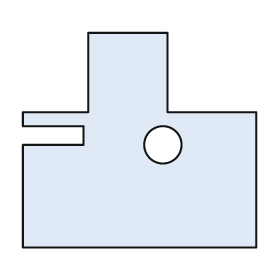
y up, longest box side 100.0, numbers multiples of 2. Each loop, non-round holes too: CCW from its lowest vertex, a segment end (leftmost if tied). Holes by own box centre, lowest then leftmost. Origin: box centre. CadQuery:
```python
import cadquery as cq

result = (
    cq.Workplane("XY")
    .moveTo(-50.0, -46.0)
    .lineTo(50.0, -46.0)
    .lineTo(50.0, 12.0)
    .lineTo(12.0, 12.0)
    .lineTo(12.0, 46.0)
    .lineTo(-22.0, 46.0)
    .lineTo(-22.0, 12.0)
    .lineTo(-50.0, 12.0)
    .lineTo(-50.0, 6.0)
    .lineTo(-24.0, 6.0)
    .lineTo(-24.0, -2.0)
    .lineTo(-50.0, -2.0)
    .close()
    .moveTo(10.0, -2.0)
    .circle(8.0)
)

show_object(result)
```